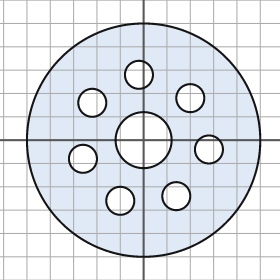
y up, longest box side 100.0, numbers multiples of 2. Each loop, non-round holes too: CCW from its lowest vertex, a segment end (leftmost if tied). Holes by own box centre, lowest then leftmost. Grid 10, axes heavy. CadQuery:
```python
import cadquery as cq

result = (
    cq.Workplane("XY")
    .moveTo(0.0, 0.0)
    .circle(50.0)
    .moveTo(-10.0, -26.0)
    .circle(6.0)
    .moveTo(14.0, -24.0)
    .circle(6.0)
    .moveTo(-26.0, -8.0)
    .circle(6.0)
    .moveTo(28.0, -4.0)
    .circle(6.0)
    .moveTo(0.0, 0.0)
    .circle(12.0)
    .moveTo(-22.0, 16.0)
    .circle(6.0)
    .moveTo(20.0, 18.0)
    .circle(6.0)
    .moveTo(-2.0, 28.0)
    .circle(6.0)
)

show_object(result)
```